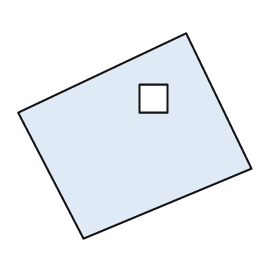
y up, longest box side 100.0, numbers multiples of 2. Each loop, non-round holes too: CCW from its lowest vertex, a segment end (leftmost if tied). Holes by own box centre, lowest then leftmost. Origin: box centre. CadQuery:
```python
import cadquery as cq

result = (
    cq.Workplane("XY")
    .moveTo(-22.0, -44.0)
    .lineTo(50.0, -14.0)
    .lineTo(22.0, 44.0)
    .lineTo(-50.0, 10.0)
    .close()
    .moveTo(2.0, 10.0)
    .lineTo(14.0, 10.0)
    .lineTo(14.0, 22.0)
    .lineTo(2.0, 22.0)
    .close()
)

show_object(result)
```